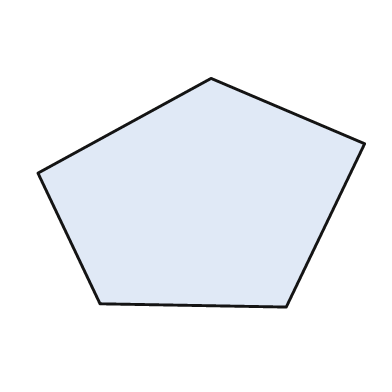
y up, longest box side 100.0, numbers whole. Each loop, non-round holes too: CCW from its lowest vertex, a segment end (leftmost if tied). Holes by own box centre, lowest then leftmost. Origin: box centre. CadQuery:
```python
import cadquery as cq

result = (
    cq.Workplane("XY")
    .moveTo(26.0, -35.0)
    .lineTo(50.0, 15.0)
    .lineTo(3.0, 35.0)
    .lineTo(-50.0, 6.0)
    .lineTo(-31.0, -34.0)
    .close()
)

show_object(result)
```